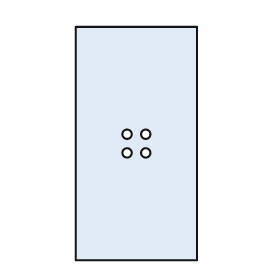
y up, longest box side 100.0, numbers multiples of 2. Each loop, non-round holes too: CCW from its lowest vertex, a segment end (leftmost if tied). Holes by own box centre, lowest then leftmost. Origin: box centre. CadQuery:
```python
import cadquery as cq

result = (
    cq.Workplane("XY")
    .moveTo(-26.0, -50.0)
    .lineTo(26.0, -50.0)
    .lineTo(26.0, 50.0)
    .lineTo(-26.0, 50.0)
    .close()
    .moveTo(-4.0, -4.0)
    .circle(2.0)
    .moveTo(4.0, -4.0)
    .circle(2.0)
    .moveTo(-4.0, 4.0)
    .circle(2.0)
    .moveTo(4.0, 4.0)
    .circle(2.0)
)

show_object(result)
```